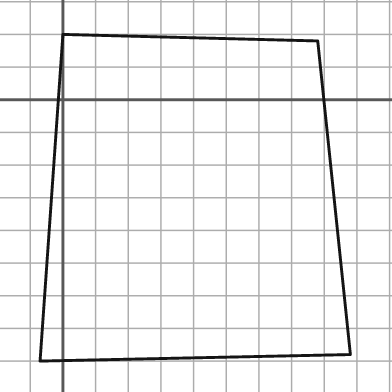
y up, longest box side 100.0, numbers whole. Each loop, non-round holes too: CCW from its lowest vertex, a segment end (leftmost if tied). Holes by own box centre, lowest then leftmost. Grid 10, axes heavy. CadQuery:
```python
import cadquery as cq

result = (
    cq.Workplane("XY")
    .moveTo(-7.0, -80.0)
    .lineTo(88.0, -78.0)
    .lineTo(78.0, 18.0)
    .lineTo(0.0, 20.0)
    .close()
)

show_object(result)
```